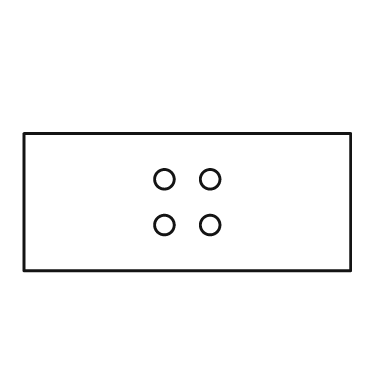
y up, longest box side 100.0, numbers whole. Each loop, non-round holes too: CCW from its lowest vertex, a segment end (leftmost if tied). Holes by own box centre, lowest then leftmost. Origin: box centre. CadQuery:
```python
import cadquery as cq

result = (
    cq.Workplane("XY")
    .moveTo(-50.0, -21.0)
    .lineTo(50.0, -21.0)
    .lineTo(50.0, 21.0)
    .lineTo(-50.0, 21.0)
    .close()
    .moveTo(-7.0, -7.0)
    .circle(3.0)
    .moveTo(7.0, -7.0)
    .circle(3.0)
    .moveTo(-7.0, 7.0)
    .circle(3.0)
    .moveTo(7.0, 7.0)
    .circle(3.0)
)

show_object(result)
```